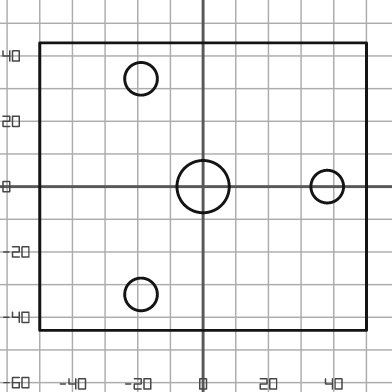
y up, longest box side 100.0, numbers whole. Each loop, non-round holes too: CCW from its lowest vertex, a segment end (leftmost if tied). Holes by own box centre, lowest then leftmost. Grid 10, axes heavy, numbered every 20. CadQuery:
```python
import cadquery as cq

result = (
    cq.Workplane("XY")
    .moveTo(-50.0, -44.0)
    .lineTo(50.0, -44.0)
    .lineTo(50.0, 44.0)
    .lineTo(-50.0, 44.0)
    .close()
    .moveTo(-19.0, -33.0)
    .circle(5.0)
    .moveTo(0.0, 0.0)
    .circle(8.0)
    .moveTo(38.0, 0.0)
    .circle(5.0)
    .moveTo(-19.0, 33.0)
    .circle(5.0)
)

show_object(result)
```